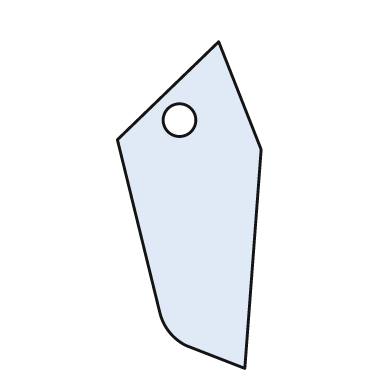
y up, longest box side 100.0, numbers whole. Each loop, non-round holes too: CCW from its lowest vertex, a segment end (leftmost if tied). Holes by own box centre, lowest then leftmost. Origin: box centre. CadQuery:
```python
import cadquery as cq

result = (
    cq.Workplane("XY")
    .moveTo(17.0, -50.0)
    .lineTo(22.0, 17.0)
    .lineTo(9.0, 50.0)
    .lineTo(-22.0, 20.0)
    .lineTo(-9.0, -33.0)
    .threePointArc((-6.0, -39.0), (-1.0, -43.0))
    .close()
    .moveTo(-3.0, 26.0)
    .circle(5.0)
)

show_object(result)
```